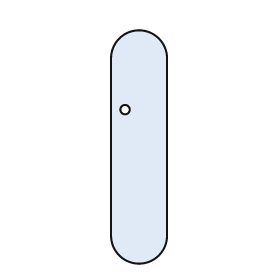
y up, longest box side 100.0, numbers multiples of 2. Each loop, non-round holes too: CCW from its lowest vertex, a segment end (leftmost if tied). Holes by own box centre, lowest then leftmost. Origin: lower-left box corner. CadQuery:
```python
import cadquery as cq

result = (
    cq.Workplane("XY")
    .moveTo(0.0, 12.0)
    .threePointArc((12.0, 0.0), (24.0, 12.0))
    .lineTo(24.0, 88.0)
    .threePointArc((12.0, 100.0), (0.0, 88.0))
    .close()
    .moveTo(6.0, 66.0)
    .circle(2.0)
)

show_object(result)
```